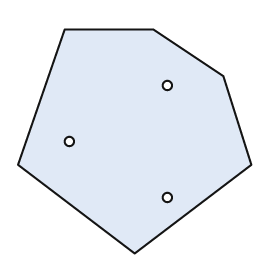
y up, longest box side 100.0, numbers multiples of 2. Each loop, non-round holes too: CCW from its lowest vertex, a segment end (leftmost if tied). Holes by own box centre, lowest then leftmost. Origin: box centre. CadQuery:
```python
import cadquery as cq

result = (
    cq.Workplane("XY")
    .moveTo(0.0, -48.0)
    .lineTo(50.0, -10.0)
    .lineTo(38.0, 28.0)
    .lineTo(8.0, 48.0)
    .lineTo(-30.0, 48.0)
    .lineTo(-50.0, -10.0)
    .close()
    .moveTo(14.0, -24.0)
    .circle(2.0)
    .moveTo(-28.0, 0.0)
    .circle(2.0)
    .moveTo(14.0, 24.0)
    .circle(2.0)
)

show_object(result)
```